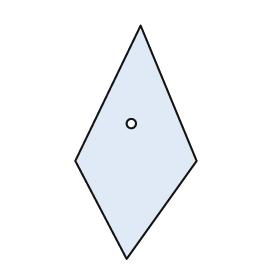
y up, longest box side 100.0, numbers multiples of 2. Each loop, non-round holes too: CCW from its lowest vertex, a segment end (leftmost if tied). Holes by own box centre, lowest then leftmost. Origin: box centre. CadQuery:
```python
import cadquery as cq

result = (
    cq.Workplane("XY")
    .moveTo(-4.0, -50.0)
    .lineTo(26.0, -8.0)
    .lineTo(2.0, 50.0)
    .lineTo(-26.0, -8.0)
    .close()
    .moveTo(-2.0, 8.0)
    .circle(2.0)
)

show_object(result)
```